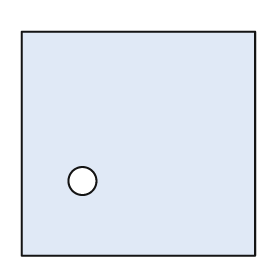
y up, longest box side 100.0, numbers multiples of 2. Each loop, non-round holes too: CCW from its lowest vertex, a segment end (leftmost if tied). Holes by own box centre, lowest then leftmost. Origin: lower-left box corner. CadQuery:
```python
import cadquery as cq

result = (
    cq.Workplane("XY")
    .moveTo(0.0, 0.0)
    .lineTo(100.0, 0.0)
    .lineTo(100.0, 96.0)
    .lineTo(0.0, 96.0)
    .close()
    .moveTo(26.0, 32.0)
    .circle(6.0)
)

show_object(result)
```